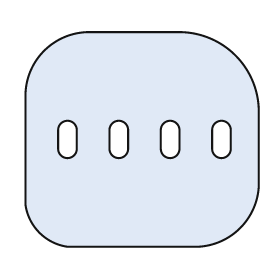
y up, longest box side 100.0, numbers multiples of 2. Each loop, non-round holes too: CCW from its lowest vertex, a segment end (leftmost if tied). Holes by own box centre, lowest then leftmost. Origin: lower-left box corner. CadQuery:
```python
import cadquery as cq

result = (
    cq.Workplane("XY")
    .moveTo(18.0, 0.0)
    .lineTo(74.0, 0.0)
    .threePointArc((92.0, 8.0), (100.0, 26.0))
    .lineTo(100.0, 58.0)
    .threePointArc((90.0, 82.0), (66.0, 92.0))
    .lineTo(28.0, 92.0)
    .threePointArc((8.0, 84.0), (0.0, 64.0))
    .lineTo(0.0, 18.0)
    .threePointArc((6.0, 6.0), (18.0, 0.0))
    .close()
    .moveTo(14.0, 42.0)
    .threePointArc((18.0, 38.0), (22.0, 42.0))
    .lineTo(22.0, 50.0)
    .threePointArc((18.0, 54.0), (14.0, 50.0))
    .close()
    .moveTo(36.0, 42.0)
    .threePointArc((40.0, 38.0), (44.0, 42.0))
    .lineTo(44.0, 50.0)
    .threePointArc((40.0, 54.0), (36.0, 50.0))
    .close()
    .moveTo(58.0, 42.0)
    .threePointArc((62.0, 38.0), (66.0, 42.0))
    .lineTo(66.0, 50.0)
    .threePointArc((62.0, 54.0), (58.0, 50.0))
    .close()
    .moveTo(80.0, 42.0)
    .threePointArc((84.0, 38.0), (88.0, 42.0))
    .lineTo(88.0, 50.0)
    .threePointArc((84.0, 54.0), (80.0, 50.0))
    .close()
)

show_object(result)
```